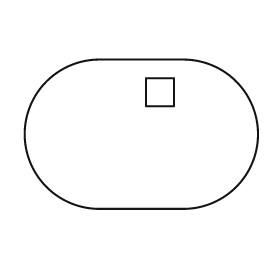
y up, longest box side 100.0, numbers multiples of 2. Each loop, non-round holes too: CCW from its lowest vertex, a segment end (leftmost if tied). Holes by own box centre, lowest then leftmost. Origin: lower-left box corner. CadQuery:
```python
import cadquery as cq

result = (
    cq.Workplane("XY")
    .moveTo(32.0, 0.0)
    .lineTo(68.0, 0.0)
    .threePointArc((100.0, 32.0), (68.0, 64.0))
    .lineTo(32.0, 64.0)
    .threePointArc((0.0, 32.0), (32.0, 0.0))
    .close()
    .moveTo(52.0, 44.0)
    .lineTo(64.0, 44.0)
    .lineTo(64.0, 56.0)
    .lineTo(52.0, 56.0)
    .close()
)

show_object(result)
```